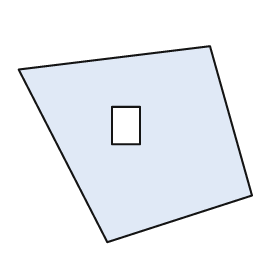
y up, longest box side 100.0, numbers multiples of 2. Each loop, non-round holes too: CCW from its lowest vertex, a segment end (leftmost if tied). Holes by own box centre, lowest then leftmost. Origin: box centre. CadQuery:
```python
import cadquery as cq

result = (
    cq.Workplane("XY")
    .moveTo(-12.0, -42.0)
    .lineTo(50.0, -22.0)
    .lineTo(32.0, 42.0)
    .lineTo(-50.0, 32.0)
    .close()
    .moveTo(-10.0, 0.0)
    .lineTo(2.0, 0.0)
    .lineTo(2.0, 16.0)
    .lineTo(-10.0, 16.0)
    .close()
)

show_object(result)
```